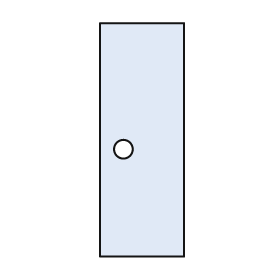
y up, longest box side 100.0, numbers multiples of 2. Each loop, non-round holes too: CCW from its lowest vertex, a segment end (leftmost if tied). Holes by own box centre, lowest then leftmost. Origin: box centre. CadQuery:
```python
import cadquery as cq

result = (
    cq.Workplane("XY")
    .moveTo(-18.0, -50.0)
    .lineTo(18.0, -50.0)
    .lineTo(18.0, 50.0)
    .lineTo(-18.0, 50.0)
    .close()
    .moveTo(-8.0, -4.0)
    .circle(4.0)
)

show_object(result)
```